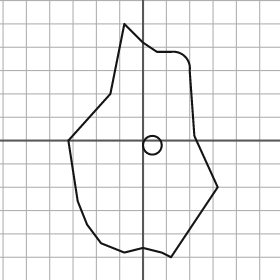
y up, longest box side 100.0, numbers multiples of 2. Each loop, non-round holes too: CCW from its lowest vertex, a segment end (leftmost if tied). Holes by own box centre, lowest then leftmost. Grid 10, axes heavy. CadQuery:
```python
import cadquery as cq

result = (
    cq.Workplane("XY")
    .moveTo(12.0, -50.0)
    .lineTo(32.0, -20.0)
    .lineTo(22.0, 2.0)
    .lineTo(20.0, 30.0)
    .threePointArc((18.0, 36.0), (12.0, 38.0))
    .lineTo(6.0, 38.0)
    .lineTo(0.0, 42.0)
    .lineTo(-8.0, 50.0)
    .lineTo(-14.0, 20.0)
    .lineTo(-32.0, 0.0)
    .lineTo(-28.0, -26.0)
    .lineTo(-24.0, -36.0)
    .lineTo(-18.0, -44.0)
    .lineTo(-8.0, -48.0)
    .lineTo(0.0, -46.0)
    .lineTo(8.0, -48.0)
    .close()
    .moveTo(4.0, -2.0)
    .circle(4.0)
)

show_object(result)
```